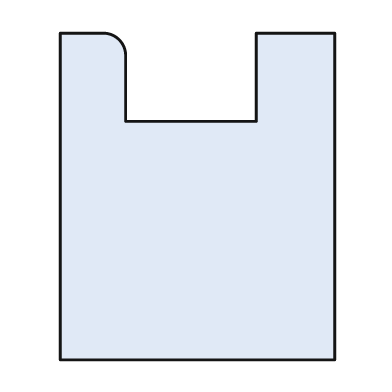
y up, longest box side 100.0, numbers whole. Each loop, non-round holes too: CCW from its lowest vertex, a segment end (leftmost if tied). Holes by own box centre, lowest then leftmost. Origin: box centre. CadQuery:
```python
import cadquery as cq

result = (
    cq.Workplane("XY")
    .moveTo(-42.0, -50.0)
    .lineTo(42.0, -50.0)
    .lineTo(42.0, 50.0)
    .lineTo(18.0, 50.0)
    .lineTo(18.0, 23.0)
    .lineTo(-22.0, 23.0)
    .lineTo(-22.0, 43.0)
    .threePointArc((-24.0, 48.0), (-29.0, 50.0))
    .lineTo(-42.0, 50.0)
    .close()
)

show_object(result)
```